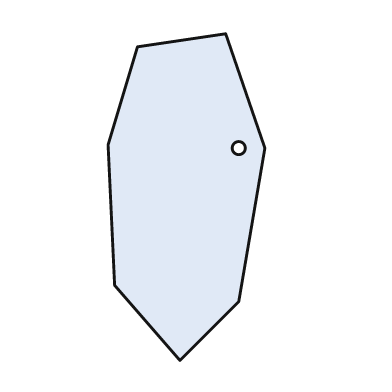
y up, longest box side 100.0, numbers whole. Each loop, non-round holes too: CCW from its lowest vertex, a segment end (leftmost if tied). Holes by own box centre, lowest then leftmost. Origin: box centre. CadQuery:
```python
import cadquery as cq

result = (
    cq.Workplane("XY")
    .moveTo(-2.0, -50.0)
    .lineTo(16.0, -32.0)
    .lineTo(24.0, 15.0)
    .lineTo(12.0, 50.0)
    .lineTo(-15.0, 46.0)
    .lineTo(-24.0, 16.0)
    .lineTo(-22.0, -27.0)
    .close()
    .moveTo(16.0, 15.0)
    .circle(2.0)
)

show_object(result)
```